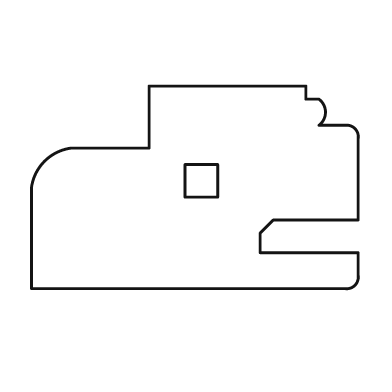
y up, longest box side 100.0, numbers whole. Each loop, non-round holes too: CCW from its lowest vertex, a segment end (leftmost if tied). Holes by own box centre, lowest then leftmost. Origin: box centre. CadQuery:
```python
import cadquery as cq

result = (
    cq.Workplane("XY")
    .moveTo(-50.0, -31.0)
    .lineTo(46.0, -31.0)
    .threePointArc((49.0, -30.0), (50.0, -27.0))
    .lineTo(50.0, -20.0)
    .lineTo(20.0, -20.0)
    .lineTo(20.0, -14.0)
    .lineTo(24.0, -10.0)
    .lineTo(50.0, -10.0)
    .lineTo(50.0, 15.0)
    .threePointArc((49.0, 18.0), (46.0, 19.0))
    .lineTo(38.0, 19.0)
    .threePointArc((40.0, 23.0), (38.0, 27.0))
    .lineTo(34.0, 27.0)
    .lineTo(34.0, 31.0)
    .lineTo(-14.0, 31.0)
    .lineTo(-14.0, 12.0)
    .lineTo(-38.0, 12.0)
    .threePointArc((-46.0, 8.0), (-50.0, 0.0))
    .close()
    .moveTo(-3.0, -3.0)
    .lineTo(7.0, -3.0)
    .lineTo(7.0, 7.0)
    .lineTo(-3.0, 7.0)
    .close()
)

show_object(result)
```